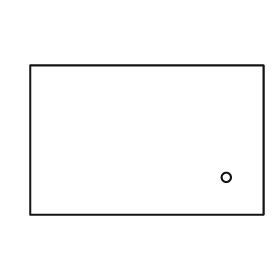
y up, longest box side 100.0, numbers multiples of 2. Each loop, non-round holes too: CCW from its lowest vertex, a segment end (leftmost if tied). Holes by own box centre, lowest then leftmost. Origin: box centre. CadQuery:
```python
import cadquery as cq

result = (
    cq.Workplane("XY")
    .moveTo(-50.0, -32.0)
    .lineTo(50.0, -32.0)
    .lineTo(50.0, 32.0)
    .lineTo(-50.0, 32.0)
    .close()
    .moveTo(34.0, -16.0)
    .circle(2.0)
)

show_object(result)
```